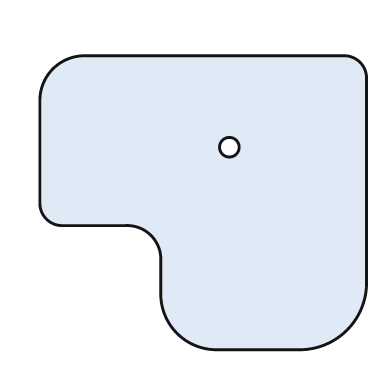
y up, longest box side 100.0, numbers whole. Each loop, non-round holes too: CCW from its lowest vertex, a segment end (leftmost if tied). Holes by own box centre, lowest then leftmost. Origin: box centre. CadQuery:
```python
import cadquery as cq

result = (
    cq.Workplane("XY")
    .moveTo(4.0, -45.0)
    .lineTo(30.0, -45.0)
    .threePointArc((44.0, -39.0), (50.0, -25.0))
    .lineTo(50.0, 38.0)
    .threePointArc((48.0, 43.0), (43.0, 45.0))
    .lineTo(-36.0, 45.0)
    .threePointArc((-46.0, 41.0), (-50.0, 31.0))
    .lineTo(-50.0, 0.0)
    .threePointArc((-48.0, -5.0), (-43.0, -7.0))
    .lineTo(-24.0, -7.0)
    .threePointArc((-16.0, -10.0), (-13.0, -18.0))
    .lineTo(-13.0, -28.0)
    .threePointArc((-8.0, -40.0), (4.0, -45.0))
    .close()
    .moveTo(8.0, 17.0)
    .circle(3.0)
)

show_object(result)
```